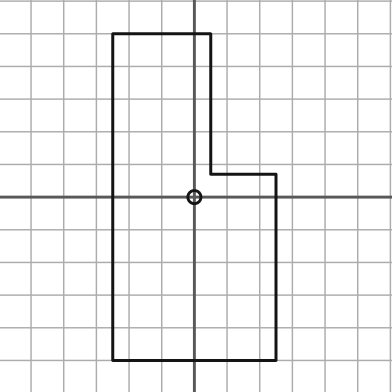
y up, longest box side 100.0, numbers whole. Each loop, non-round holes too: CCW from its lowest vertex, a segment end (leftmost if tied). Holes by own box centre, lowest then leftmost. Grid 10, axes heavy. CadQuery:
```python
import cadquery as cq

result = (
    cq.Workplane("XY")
    .moveTo(-25.0, -50.0)
    .lineTo(25.0, -50.0)
    .lineTo(25.0, 7.0)
    .lineTo(5.0, 7.0)
    .lineTo(5.0, 50.0)
    .lineTo(-25.0, 50.0)
    .close()
    .moveTo(0.0, 0.0)
    .circle(2.0)
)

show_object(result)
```